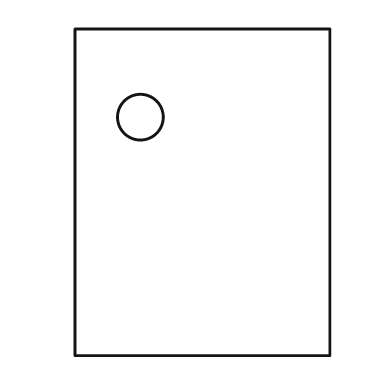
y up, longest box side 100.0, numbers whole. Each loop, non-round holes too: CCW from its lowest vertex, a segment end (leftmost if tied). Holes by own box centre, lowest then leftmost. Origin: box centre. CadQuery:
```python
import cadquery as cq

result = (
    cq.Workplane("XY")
    .moveTo(-39.0, -50.0)
    .lineTo(39.0, -50.0)
    .lineTo(39.0, 50.0)
    .lineTo(-39.0, 50.0)
    .close()
    .moveTo(-19.0, 23.0)
    .circle(7.0)
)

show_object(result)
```